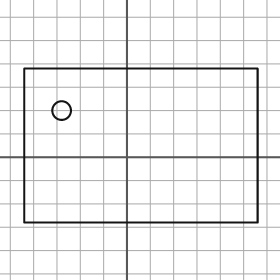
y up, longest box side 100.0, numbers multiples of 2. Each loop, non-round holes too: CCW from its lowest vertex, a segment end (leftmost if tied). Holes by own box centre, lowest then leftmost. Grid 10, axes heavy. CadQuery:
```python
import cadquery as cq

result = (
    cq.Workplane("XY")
    .moveTo(-44.0, -28.0)
    .lineTo(56.0, -28.0)
    .lineTo(56.0, 38.0)
    .lineTo(-44.0, 38.0)
    .close()
    .moveTo(-28.0, 20.0)
    .circle(4.0)
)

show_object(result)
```